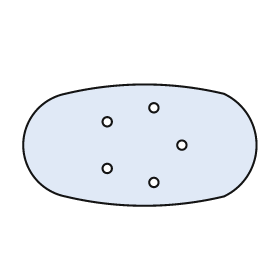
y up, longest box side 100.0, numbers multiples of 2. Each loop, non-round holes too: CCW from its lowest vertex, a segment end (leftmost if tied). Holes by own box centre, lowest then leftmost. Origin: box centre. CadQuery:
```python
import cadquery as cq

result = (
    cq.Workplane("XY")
    .moveTo(-32.0, -22.0)
    .threePointArc((2.0, -26.0), (36.0, -22.0))
    .threePointArc((50.0, 0.0), (36.0, 22.0))
    .threePointArc((2.0, 26.0), (-32.0, 22.0))
    .threePointArc((-50.0, 0.0), (-32.0, -22.0))
    .close()
    .moveTo(6.0, -16.0)
    .circle(2.0)
    .moveTo(-14.0, -10.0)
    .circle(2.0)
    .moveTo(18.0, 0.0)
    .circle(2.0)
    .moveTo(-14.0, 10.0)
    .circle(2.0)
    .moveTo(6.0, 16.0)
    .circle(2.0)
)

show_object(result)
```